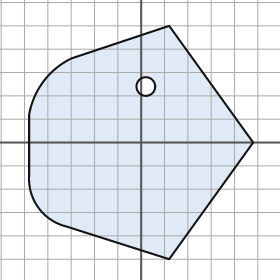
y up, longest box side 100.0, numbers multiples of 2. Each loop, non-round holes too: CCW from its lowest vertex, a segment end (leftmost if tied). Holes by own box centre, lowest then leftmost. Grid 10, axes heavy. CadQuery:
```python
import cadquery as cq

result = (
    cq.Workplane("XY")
    .moveTo(12.0, -50.0)
    .lineTo(48.0, 0.0)
    .lineTo(12.0, 50.0)
    .lineTo(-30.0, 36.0)
    .threePointArc((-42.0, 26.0), (-48.0, 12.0))
    .lineTo(-48.0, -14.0)
    .threePointArc((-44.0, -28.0), (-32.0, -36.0))
    .close()
    .moveTo(2.0, 24.0)
    .circle(4.0)
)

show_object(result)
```